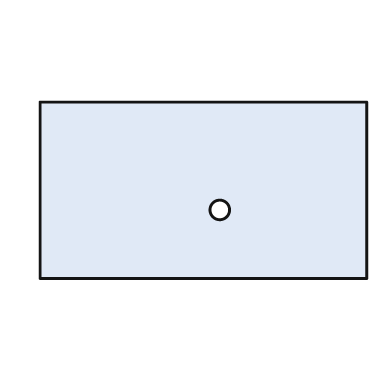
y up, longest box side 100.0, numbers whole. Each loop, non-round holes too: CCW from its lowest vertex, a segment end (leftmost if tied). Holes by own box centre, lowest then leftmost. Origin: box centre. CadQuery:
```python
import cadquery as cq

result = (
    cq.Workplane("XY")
    .moveTo(-50.0, -27.0)
    .lineTo(50.0, -27.0)
    .lineTo(50.0, 27.0)
    .lineTo(-50.0, 27.0)
    .close()
    .moveTo(5.0, -6.0)
    .circle(3.0)
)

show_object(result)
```